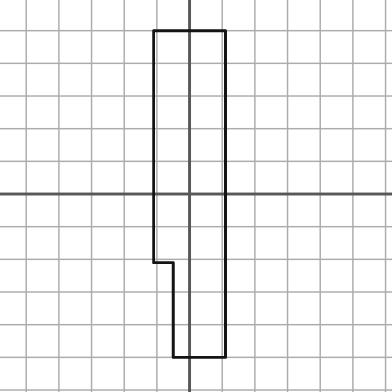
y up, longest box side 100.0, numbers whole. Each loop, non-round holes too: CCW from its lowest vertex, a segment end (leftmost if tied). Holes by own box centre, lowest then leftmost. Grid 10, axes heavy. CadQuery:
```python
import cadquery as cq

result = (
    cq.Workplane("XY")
    .moveTo(-5.0, -50.0)
    .lineTo(11.0, -50.0)
    .lineTo(11.0, 50.0)
    .lineTo(-11.0, 50.0)
    .lineTo(-11.0, -21.0)
    .lineTo(-5.0, -21.0)
    .close()
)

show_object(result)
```